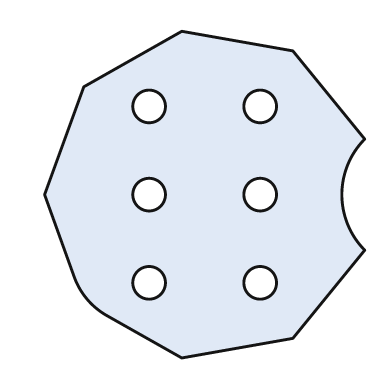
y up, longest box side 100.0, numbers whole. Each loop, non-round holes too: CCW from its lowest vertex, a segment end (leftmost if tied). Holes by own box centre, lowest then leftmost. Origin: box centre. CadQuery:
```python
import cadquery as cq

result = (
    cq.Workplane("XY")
    .moveTo(-7.0, -50.0)
    .lineTo(27.0, -44.0)
    .lineTo(49.0, -17.0)
    .threePointArc((42.0, 0.0), (49.0, 17.0))
    .lineTo(27.0, 44.0)
    .lineTo(-7.0, 50.0)
    .lineTo(-37.0, 33.0)
    .lineTo(-49.0, 0.0)
    .lineTo(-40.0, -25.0)
    .threePointArc((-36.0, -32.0), (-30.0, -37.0))
    .close()
    .moveTo(-17.0, -27.0)
    .circle(5.0)
    .moveTo(17.0, -27.0)
    .circle(5.0)
    .moveTo(-17.0, 0.0)
    .circle(5.0)
    .moveTo(17.0, 0.0)
    .circle(5.0)
    .moveTo(-17.0, 27.0)
    .circle(5.0)
    .moveTo(17.0, 27.0)
    .circle(5.0)
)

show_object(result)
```